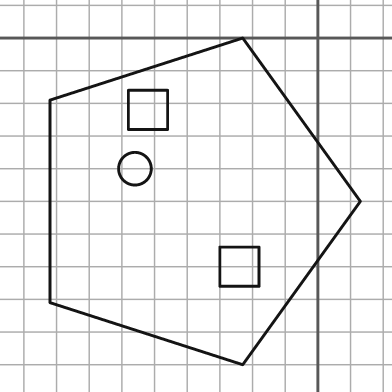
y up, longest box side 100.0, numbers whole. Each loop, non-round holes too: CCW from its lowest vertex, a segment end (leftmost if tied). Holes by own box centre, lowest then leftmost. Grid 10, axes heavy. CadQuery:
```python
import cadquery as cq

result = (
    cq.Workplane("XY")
    .moveTo(-23.0, -100.0)
    .lineTo(13.0, -50.0)
    .lineTo(-23.0, 0.0)
    .lineTo(-82.0, -19.0)
    .lineTo(-82.0, -81.0)
    .close()
    .moveTo(-30.0, -76.0)
    .lineTo(-18.0, -76.0)
    .lineTo(-18.0, -64.0)
    .lineTo(-30.0, -64.0)
    .close()
    .moveTo(-56.0, -40.0)
    .circle(5.0)
    .moveTo(-58.0, -28.0)
    .lineTo(-46.0, -28.0)
    .lineTo(-46.0, -16.0)
    .lineTo(-58.0, -16.0)
    .close()
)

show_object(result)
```